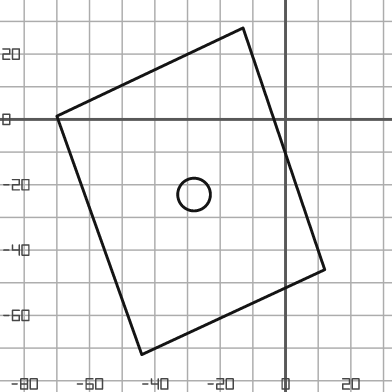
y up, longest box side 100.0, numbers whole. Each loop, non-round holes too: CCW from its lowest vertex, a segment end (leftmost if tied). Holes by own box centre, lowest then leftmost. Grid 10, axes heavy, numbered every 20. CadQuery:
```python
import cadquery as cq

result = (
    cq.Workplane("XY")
    .moveTo(-44.0, -72.0)
    .lineTo(12.0, -46.0)
    .lineTo(-13.0, 28.0)
    .lineTo(-70.0, 1.0)
    .close()
    .moveTo(-28.0, -23.0)
    .circle(5.0)
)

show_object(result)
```